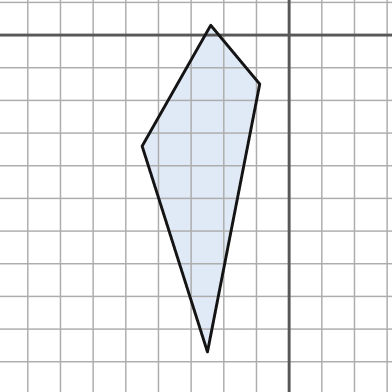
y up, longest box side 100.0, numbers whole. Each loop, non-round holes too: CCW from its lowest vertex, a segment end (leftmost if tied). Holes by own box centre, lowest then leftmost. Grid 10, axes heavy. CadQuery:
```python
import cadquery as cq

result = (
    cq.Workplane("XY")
    .moveTo(-25.0, -97.0)
    .lineTo(-9.0, -15.0)
    .lineTo(-24.0, 3.0)
    .lineTo(-45.0, -34.0)
    .close()
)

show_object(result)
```